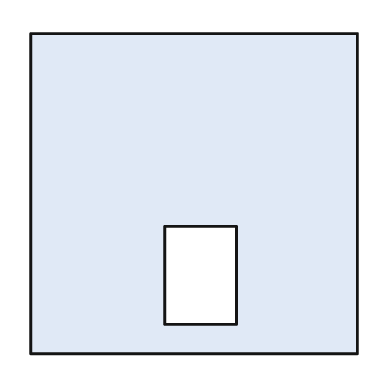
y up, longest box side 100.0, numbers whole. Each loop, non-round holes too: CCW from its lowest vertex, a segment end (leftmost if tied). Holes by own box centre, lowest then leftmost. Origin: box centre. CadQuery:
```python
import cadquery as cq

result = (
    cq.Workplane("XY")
    .moveTo(-50.0, -49.0)
    .lineTo(50.0, -49.0)
    .lineTo(50.0, 49.0)
    .lineTo(-50.0, 49.0)
    .close()
    .moveTo(-9.0, -40.0)
    .lineTo(13.0, -40.0)
    .lineTo(13.0, -10.0)
    .lineTo(-9.0, -10.0)
    .close()
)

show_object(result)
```